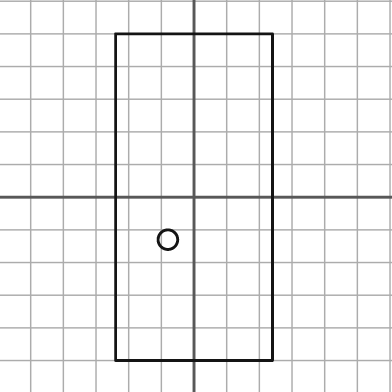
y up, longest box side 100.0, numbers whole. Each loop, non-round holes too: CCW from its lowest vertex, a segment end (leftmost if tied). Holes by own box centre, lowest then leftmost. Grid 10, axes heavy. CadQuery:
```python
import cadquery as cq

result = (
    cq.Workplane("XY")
    .moveTo(-24.0, -50.0)
    .lineTo(24.0, -50.0)
    .lineTo(24.0, 50.0)
    .lineTo(-24.0, 50.0)
    .close()
    .moveTo(-8.0, -13.0)
    .circle(3.0)
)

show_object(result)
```